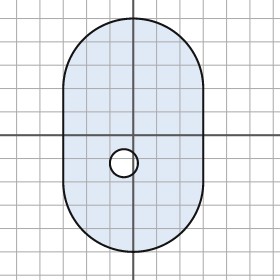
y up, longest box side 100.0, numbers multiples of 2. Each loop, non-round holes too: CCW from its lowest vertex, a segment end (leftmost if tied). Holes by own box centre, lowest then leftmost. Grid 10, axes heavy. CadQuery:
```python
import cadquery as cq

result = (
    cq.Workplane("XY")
    .moveTo(-30.0, -20.0)
    .threePointArc((0.0, -50.0), (30.0, -20.0))
    .lineTo(30.0, 20.0)
    .threePointArc((0.0, 50.0), (-30.0, 20.0))
    .close()
    .moveTo(-4.0, -12.0)
    .circle(6.0)
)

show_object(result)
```